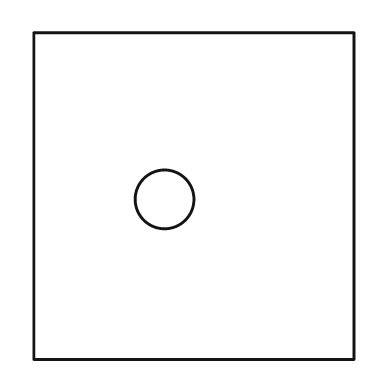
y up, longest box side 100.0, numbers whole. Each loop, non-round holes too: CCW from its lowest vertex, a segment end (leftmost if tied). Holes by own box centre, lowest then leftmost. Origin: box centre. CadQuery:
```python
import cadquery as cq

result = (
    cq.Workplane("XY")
    .moveTo(-49.0, -50.0)
    .lineTo(49.0, -50.0)
    .lineTo(49.0, 50.0)
    .lineTo(-49.0, 50.0)
    .close()
    .moveTo(-9.0, -1.0)
    .circle(9.0)
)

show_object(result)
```